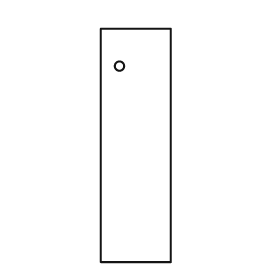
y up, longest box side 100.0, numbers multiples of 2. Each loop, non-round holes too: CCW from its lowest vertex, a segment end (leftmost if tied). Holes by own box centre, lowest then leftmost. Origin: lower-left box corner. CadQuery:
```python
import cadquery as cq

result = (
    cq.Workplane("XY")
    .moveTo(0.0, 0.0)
    .lineTo(30.0, 0.0)
    .lineTo(30.0, 100.0)
    .lineTo(0.0, 100.0)
    .close()
    .moveTo(8.0, 84.0)
    .circle(2.0)
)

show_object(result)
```